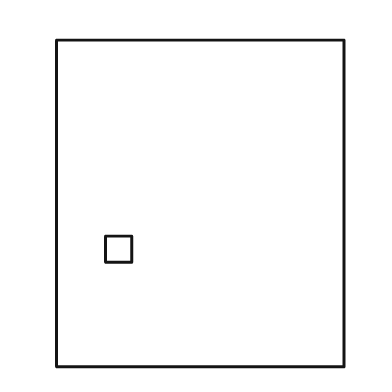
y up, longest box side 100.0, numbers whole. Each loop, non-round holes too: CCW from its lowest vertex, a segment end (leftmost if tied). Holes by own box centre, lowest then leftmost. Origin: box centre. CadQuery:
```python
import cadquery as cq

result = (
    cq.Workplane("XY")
    .moveTo(-44.0, -50.0)
    .lineTo(44.0, -50.0)
    .lineTo(44.0, 50.0)
    .lineTo(-44.0, 50.0)
    .close()
    .moveTo(-29.0, -18.0)
    .lineTo(-21.0, -18.0)
    .lineTo(-21.0, -10.0)
    .lineTo(-29.0, -10.0)
    .close()
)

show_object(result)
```